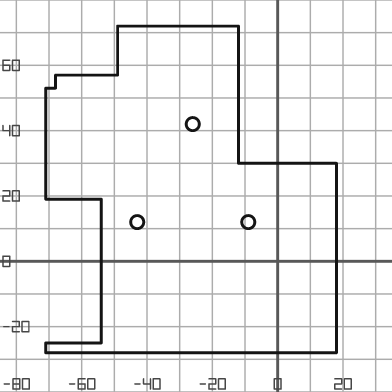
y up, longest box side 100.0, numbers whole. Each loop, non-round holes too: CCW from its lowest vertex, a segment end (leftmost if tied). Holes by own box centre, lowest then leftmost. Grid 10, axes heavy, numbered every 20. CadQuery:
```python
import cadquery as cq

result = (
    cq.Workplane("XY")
    .moveTo(-71.0, -28.0)
    .lineTo(18.0, -28.0)
    .lineTo(18.0, 30.0)
    .lineTo(-12.0, 30.0)
    .lineTo(-12.0, 72.0)
    .lineTo(-49.0, 72.0)
    .lineTo(-49.0, 57.0)
    .lineTo(-68.0, 57.0)
    .lineTo(-68.0, 53.0)
    .lineTo(-71.0, 53.0)
    .lineTo(-71.0, 19.0)
    .lineTo(-54.0, 19.0)
    .lineTo(-54.0, -25.0)
    .lineTo(-71.0, -25.0)
    .close()
    .moveTo(-43.0, 12.0)
    .circle(2.0)
    .moveTo(-9.0, 12.0)
    .circle(2.0)
    .moveTo(-26.0, 42.0)
    .circle(2.0)
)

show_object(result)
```